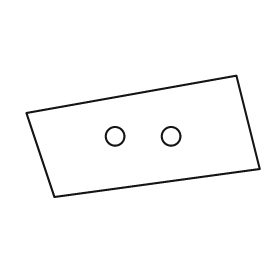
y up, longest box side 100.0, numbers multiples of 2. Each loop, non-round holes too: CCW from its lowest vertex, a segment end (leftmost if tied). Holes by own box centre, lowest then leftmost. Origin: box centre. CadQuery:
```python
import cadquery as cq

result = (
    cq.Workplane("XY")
    .moveTo(-38.0, -26.0)
    .lineTo(50.0, -14.0)
    .lineTo(40.0, 26.0)
    .lineTo(-50.0, 10.0)
    .close()
    .moveTo(-12.0, 0.0)
    .circle(4.0)
    .moveTo(12.0, 0.0)
    .circle(4.0)
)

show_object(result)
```